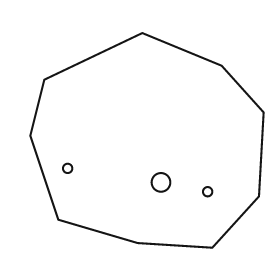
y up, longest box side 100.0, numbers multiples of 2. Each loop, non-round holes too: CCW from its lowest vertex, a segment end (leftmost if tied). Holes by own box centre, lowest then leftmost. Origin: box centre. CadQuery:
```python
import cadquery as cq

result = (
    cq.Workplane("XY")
    .moveTo(28.0, -46.0)
    .lineTo(48.0, -24.0)
    .lineTo(50.0, 12.0)
    .lineTo(32.0, 32.0)
    .lineTo(-2.0, 46.0)
    .lineTo(-44.0, 26.0)
    .lineTo(-50.0, 2.0)
    .lineTo(-38.0, -34.0)
    .lineTo(-4.0, -44.0)
    .close()
    .moveTo(26.0, -22.0)
    .circle(2.0)
    .moveTo(6.0, -18.0)
    .circle(4.0)
    .moveTo(-34.0, -12.0)
    .circle(2.0)
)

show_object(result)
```